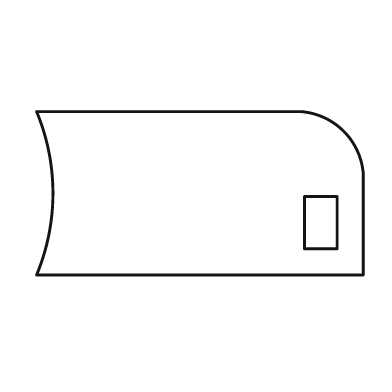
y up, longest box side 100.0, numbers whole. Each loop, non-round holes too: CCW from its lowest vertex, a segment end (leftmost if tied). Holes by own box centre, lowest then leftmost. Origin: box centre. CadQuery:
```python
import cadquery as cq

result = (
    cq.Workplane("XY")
    .moveTo(-50.0, -25.0)
    .lineTo(50.0, -25.0)
    .lineTo(50.0, 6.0)
    .threePointArc((44.0, 19.0), (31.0, 25.0))
    .lineTo(-50.0, 25.0)
    .threePointArc((-45.0, 0.0), (-50.0, -25.0))
    .close()
    .moveTo(32.0, -17.0)
    .lineTo(42.0, -17.0)
    .lineTo(42.0, -1.0)
    .lineTo(32.0, -1.0)
    .close()
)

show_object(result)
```